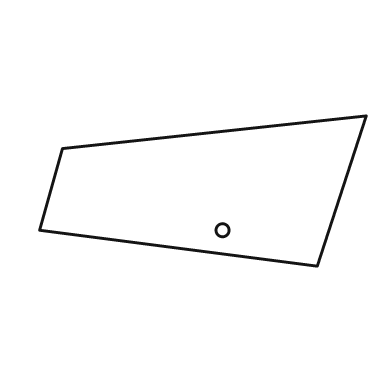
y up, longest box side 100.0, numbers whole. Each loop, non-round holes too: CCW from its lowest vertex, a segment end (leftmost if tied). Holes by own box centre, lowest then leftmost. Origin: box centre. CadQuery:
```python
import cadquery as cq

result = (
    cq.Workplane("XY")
    .moveTo(35.0, -23.0)
    .lineTo(50.0, 23.0)
    .lineTo(-43.0, 13.0)
    .lineTo(-50.0, -12.0)
    .close()
    .moveTo(6.0, -12.0)
    .circle(2.0)
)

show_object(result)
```